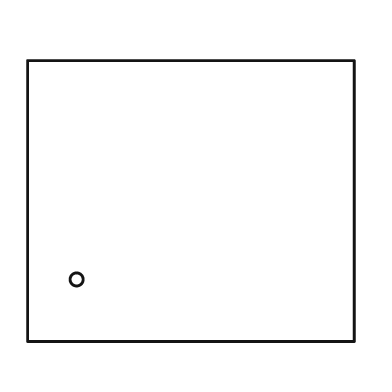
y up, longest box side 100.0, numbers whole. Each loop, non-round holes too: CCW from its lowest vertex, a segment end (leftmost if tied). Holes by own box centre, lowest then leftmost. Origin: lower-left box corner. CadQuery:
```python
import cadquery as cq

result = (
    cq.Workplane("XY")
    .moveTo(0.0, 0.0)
    .lineTo(100.0, 0.0)
    .lineTo(100.0, 86.0)
    .lineTo(0.0, 86.0)
    .close()
    .moveTo(15.0, 19.0)
    .circle(2.0)
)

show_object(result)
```